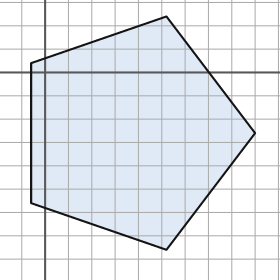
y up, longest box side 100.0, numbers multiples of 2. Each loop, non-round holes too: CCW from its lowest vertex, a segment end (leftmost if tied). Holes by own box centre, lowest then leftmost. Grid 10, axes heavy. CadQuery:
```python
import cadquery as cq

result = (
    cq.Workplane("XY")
    .moveTo(52.0, -76.0)
    .lineTo(90.0, -26.0)
    .lineTo(52.0, 24.0)
    .lineTo(-6.0, 4.0)
    .lineTo(-6.0, -56.0)
    .close()
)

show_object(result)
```